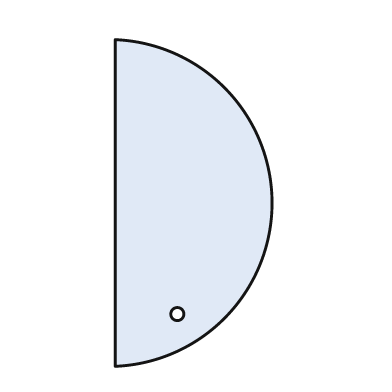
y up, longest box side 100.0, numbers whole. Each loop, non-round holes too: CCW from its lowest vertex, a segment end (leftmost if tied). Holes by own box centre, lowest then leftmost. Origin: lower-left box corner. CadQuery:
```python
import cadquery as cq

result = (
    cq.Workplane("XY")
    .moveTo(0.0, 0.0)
    .threePointArc((48.0, 50.0), (0.0, 100.0))
    .close()
    .moveTo(19.0, 16.0)
    .circle(2.0)
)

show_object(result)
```